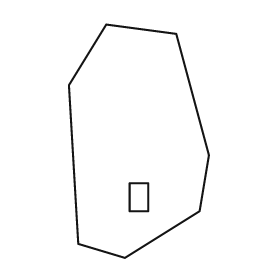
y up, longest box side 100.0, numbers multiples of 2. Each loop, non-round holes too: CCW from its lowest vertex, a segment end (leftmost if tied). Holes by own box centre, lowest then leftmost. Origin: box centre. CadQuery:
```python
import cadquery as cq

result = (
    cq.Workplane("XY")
    .moveTo(-6.0, -50.0)
    .lineTo(26.0, -30.0)
    .lineTo(30.0, -6.0)
    .lineTo(16.0, 46.0)
    .lineTo(-14.0, 50.0)
    .lineTo(-30.0, 24.0)
    .lineTo(-26.0, -44.0)
    .close()
    .moveTo(-4.0, -30.0)
    .lineTo(4.0, -30.0)
    .lineTo(4.0, -18.0)
    .lineTo(-4.0, -18.0)
    .close()
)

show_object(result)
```